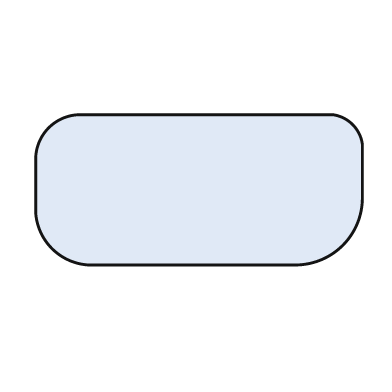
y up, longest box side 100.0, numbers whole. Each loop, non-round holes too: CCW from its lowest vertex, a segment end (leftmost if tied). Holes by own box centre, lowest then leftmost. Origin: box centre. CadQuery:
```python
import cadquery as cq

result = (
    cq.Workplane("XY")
    .moveTo(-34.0, -23.0)
    .lineTo(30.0, -23.0)
    .threePointArc((44.0, -17.0), (50.0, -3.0))
    .lineTo(50.0, 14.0)
    .threePointArc((47.0, 20.0), (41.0, 23.0))
    .lineTo(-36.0, 23.0)
    .threePointArc((-46.0, 19.0), (-50.0, 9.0))
    .lineTo(-50.0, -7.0)
    .threePointArc((-45.0, -18.0), (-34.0, -23.0))
    .close()
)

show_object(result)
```